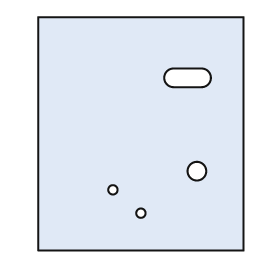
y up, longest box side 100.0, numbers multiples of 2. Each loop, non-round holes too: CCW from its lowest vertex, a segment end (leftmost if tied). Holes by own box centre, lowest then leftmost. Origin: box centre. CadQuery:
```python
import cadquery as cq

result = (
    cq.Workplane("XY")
    .moveTo(-44.0, -50.0)
    .lineTo(44.0, -50.0)
    .lineTo(44.0, 50.0)
    .lineTo(-44.0, 50.0)
    .close()
    .moveTo(0.0, -34.0)
    .circle(2.0)
    .moveTo(-12.0, -24.0)
    .circle(2.0)
    .moveTo(24.0, -16.0)
    .circle(4.0)
    .moveTo(14.0, 20.0)
    .lineTo(26.0, 20.0)
    .threePointArc((30.0, 24.0), (26.0, 28.0))
    .lineTo(14.0, 28.0)
    .threePointArc((10.0, 24.0), (14.0, 20.0))
    .close()
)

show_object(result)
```